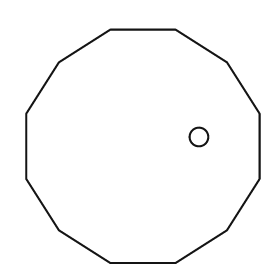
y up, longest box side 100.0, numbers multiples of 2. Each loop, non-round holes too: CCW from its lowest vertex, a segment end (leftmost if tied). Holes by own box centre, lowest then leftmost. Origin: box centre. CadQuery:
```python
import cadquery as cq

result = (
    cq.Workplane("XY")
    .moveTo(-14.0, -50.0)
    .lineTo(14.0, -50.0)
    .lineTo(36.0, -36.0)
    .lineTo(50.0, -14.0)
    .lineTo(50.0, 14.0)
    .lineTo(36.0, 36.0)
    .lineTo(14.0, 50.0)
    .lineTo(-14.0, 50.0)
    .lineTo(-36.0, 36.0)
    .lineTo(-50.0, 14.0)
    .lineTo(-50.0, -14.0)
    .lineTo(-36.0, -36.0)
    .close()
    .moveTo(24.0, 4.0)
    .circle(4.0)
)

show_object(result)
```